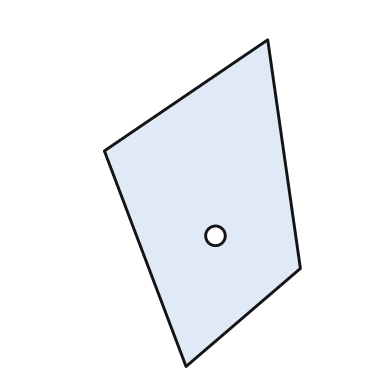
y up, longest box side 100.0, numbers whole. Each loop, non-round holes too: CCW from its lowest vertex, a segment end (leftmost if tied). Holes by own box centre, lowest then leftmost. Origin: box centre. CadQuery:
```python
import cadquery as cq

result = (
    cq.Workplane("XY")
    .moveTo(-5.0, -50.0)
    .lineTo(30.0, -20.0)
    .lineTo(20.0, 50.0)
    .lineTo(-30.0, 16.0)
    .close()
    .moveTo(4.0, -10.0)
    .circle(3.0)
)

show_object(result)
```